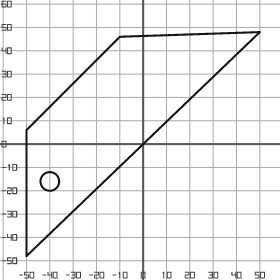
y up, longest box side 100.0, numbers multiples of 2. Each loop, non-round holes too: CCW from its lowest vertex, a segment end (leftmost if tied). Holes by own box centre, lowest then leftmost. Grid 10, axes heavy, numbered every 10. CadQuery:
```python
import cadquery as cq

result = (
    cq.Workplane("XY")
    .moveTo(-50.0, -48.0)
    .lineTo(50.0, 48.0)
    .lineTo(-10.0, 46.0)
    .lineTo(-50.0, 6.0)
    .close()
    .moveTo(-40.0, -16.0)
    .circle(4.0)
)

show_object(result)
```